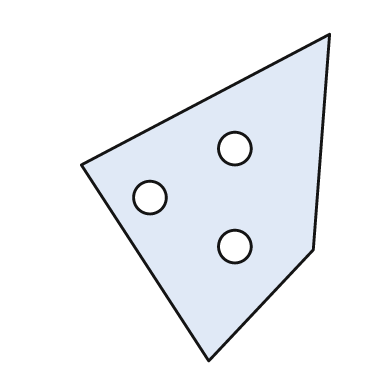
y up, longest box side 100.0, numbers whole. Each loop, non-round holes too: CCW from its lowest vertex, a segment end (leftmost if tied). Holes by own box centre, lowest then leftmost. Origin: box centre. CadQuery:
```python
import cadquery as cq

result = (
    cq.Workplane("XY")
    .moveTo(1.0, -50.0)
    .lineTo(33.0, -16.0)
    .lineTo(38.0, 50.0)
    .lineTo(-38.0, 10.0)
    .close()
    .moveTo(9.0, -15.0)
    .circle(5.0)
    .moveTo(-17.0, 0.0)
    .circle(5.0)
    .moveTo(9.0, 15.0)
    .circle(5.0)
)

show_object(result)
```